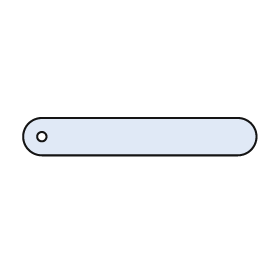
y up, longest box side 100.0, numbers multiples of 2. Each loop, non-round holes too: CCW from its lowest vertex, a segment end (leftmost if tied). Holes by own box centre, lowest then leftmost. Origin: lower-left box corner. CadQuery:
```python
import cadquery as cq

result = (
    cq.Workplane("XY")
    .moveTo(8.0, 0.0)
    .lineTo(92.0, 0.0)
    .threePointArc((100.0, 8.0), (92.0, 16.0))
    .lineTo(8.0, 16.0)
    .threePointArc((0.0, 8.0), (8.0, 0.0))
    .close()
    .moveTo(8.0, 8.0)
    .circle(2.0)
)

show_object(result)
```